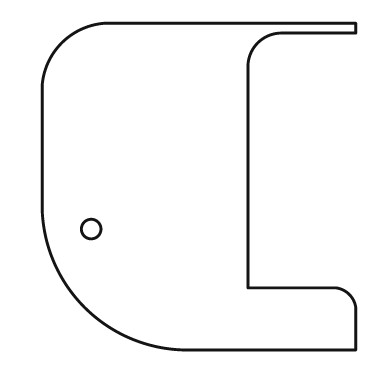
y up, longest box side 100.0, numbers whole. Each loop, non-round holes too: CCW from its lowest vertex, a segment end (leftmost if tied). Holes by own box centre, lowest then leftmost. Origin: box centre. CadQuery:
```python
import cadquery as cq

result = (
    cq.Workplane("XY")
    .moveTo(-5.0, -50.0)
    .lineTo(48.0, -50.0)
    .lineTo(48.0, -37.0)
    .threePointArc((46.0, -33.0), (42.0, -31.0))
    .lineTo(15.0, -31.0)
    .lineTo(15.0, 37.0)
    .threePointArc((18.0, 44.0), (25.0, 47.0))
    .lineTo(48.0, 47.0)
    .lineTo(48.0, 50.0)
    .lineTo(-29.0, 50.0)
    .threePointArc((-42.0, 44.0), (-48.0, 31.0))
    .lineTo(-48.0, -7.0)
    .threePointArc((-35.0, -37.0), (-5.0, -50.0))
    .close()
    .moveTo(-33.0, -13.0)
    .circle(3.0)
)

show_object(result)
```